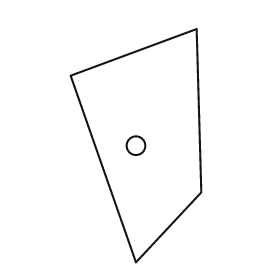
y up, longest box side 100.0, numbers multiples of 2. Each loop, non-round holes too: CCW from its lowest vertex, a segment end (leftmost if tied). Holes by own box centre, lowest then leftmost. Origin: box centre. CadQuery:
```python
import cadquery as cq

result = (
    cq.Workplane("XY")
    .moveTo(0.0, -50.0)
    .lineTo(28.0, -20.0)
    .lineTo(26.0, 50.0)
    .lineTo(-28.0, 30.0)
    .close()
    .moveTo(0.0, 0.0)
    .circle(4.0)
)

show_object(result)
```